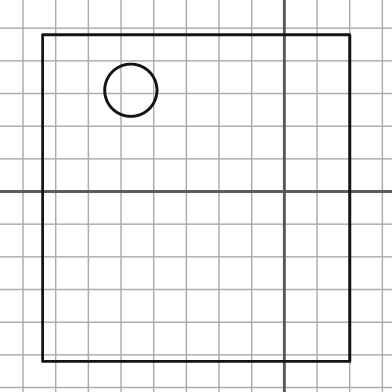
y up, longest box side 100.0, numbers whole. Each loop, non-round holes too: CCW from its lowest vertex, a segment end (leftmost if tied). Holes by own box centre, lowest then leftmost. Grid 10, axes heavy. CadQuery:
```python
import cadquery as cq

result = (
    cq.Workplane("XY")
    .moveTo(-74.0, -52.0)
    .lineTo(20.0, -52.0)
    .lineTo(20.0, 48.0)
    .lineTo(-74.0, 48.0)
    .close()
    .moveTo(-47.0, 31.0)
    .circle(8.0)
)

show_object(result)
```